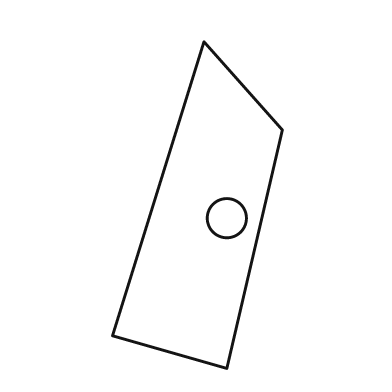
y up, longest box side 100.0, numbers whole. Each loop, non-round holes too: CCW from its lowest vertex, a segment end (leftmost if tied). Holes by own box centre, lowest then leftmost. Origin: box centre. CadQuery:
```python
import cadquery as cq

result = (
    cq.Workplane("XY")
    .moveTo(9.0, -50.0)
    .lineTo(26.0, 23.0)
    .lineTo(2.0, 50.0)
    .lineTo(-26.0, -40.0)
    .close()
    .moveTo(9.0, -4.0)
    .circle(6.0)
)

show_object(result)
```